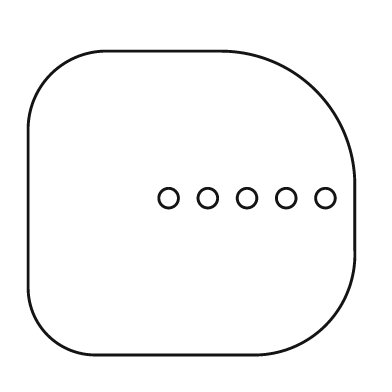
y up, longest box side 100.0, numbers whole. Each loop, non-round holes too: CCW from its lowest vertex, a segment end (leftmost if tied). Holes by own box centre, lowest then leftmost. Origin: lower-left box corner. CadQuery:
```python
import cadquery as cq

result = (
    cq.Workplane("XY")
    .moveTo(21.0, 0.0)
    .lineTo(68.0, 0.0)
    .threePointArc((91.0, 9.0), (100.0, 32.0))
    .lineTo(100.0, 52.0)
    .threePointArc((88.0, 81.0), (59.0, 93.0))
    .lineTo(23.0, 93.0)
    .threePointArc((7.0, 86.0), (0.0, 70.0))
    .lineTo(0.0, 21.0)
    .threePointArc((6.0, 6.0), (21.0, 0.0))
    .close()
    .moveTo(43.0, 48.0)
    .circle(3.0)
    .moveTo(55.0, 48.0)
    .circle(3.0)
    .moveTo(67.0, 48.0)
    .circle(3.0)
    .moveTo(79.0, 48.0)
    .circle(3.0)
    .moveTo(91.0, 48.0)
    .circle(3.0)
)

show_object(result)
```